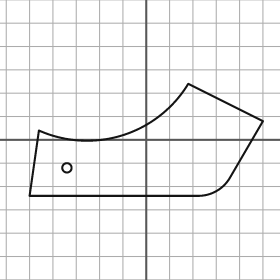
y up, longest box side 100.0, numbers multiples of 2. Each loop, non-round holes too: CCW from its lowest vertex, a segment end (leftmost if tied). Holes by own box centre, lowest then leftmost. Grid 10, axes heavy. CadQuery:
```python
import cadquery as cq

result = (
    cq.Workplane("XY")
    .moveTo(-50.0, -24.0)
    .lineTo(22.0, -24.0)
    .threePointArc((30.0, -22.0), (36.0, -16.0))
    .lineTo(50.0, 8.0)
    .lineTo(18.0, 24.0)
    .threePointArc((-10.0, 2.0), (-46.0, 4.0))
    .close()
    .moveTo(-34.0, -12.0)
    .circle(2.0)
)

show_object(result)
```